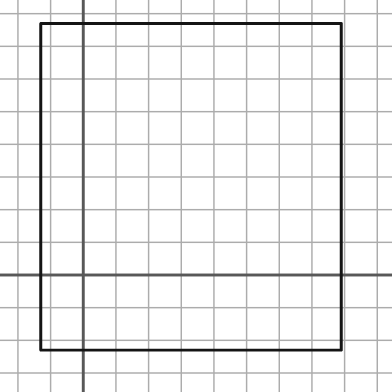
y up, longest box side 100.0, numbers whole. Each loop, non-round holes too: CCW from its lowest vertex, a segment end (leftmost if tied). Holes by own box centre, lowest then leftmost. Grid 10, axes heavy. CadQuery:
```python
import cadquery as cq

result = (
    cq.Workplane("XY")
    .moveTo(-13.0, -23.0)
    .lineTo(79.0, -23.0)
    .lineTo(79.0, 77.0)
    .lineTo(-13.0, 77.0)
    .close()
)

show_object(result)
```